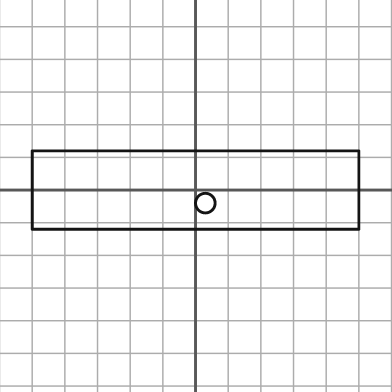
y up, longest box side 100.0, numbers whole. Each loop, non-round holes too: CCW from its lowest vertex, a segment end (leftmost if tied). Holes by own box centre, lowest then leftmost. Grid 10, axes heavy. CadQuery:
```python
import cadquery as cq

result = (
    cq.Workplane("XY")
    .moveTo(-50.0, -12.0)
    .lineTo(50.0, -12.0)
    .lineTo(50.0, 12.0)
    .lineTo(-50.0, 12.0)
    .close()
    .moveTo(3.0, -4.0)
    .circle(3.0)
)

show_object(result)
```